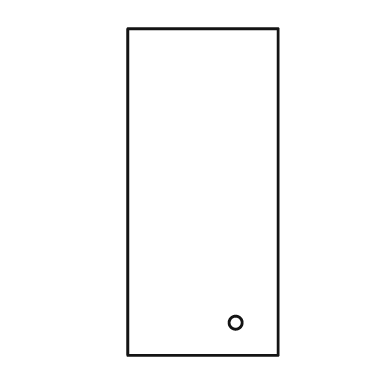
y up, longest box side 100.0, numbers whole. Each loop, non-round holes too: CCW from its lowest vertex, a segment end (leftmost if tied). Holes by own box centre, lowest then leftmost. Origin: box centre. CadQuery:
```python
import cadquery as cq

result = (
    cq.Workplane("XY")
    .moveTo(-23.0, -50.0)
    .lineTo(23.0, -50.0)
    .lineTo(23.0, 50.0)
    .lineTo(-23.0, 50.0)
    .close()
    .moveTo(10.0, -40.0)
    .circle(2.0)
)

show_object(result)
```